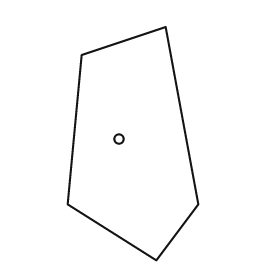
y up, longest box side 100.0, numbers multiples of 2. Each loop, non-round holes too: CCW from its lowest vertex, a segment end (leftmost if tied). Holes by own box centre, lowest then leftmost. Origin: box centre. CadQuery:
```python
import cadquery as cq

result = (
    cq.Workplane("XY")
    .moveTo(10.0, -50.0)
    .lineTo(28.0, -26.0)
    .lineTo(14.0, 50.0)
    .lineTo(-22.0, 38.0)
    .lineTo(-28.0, -26.0)
    .close()
    .moveTo(-6.0, 2.0)
    .circle(2.0)
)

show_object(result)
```